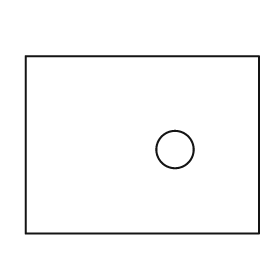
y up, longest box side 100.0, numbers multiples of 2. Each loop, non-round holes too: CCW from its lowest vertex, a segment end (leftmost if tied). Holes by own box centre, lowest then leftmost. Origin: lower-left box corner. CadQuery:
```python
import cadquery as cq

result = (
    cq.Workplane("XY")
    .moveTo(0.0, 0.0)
    .lineTo(100.0, 0.0)
    .lineTo(100.0, 76.0)
    .lineTo(0.0, 76.0)
    .close()
    .moveTo(64.0, 36.0)
    .circle(8.0)
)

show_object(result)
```